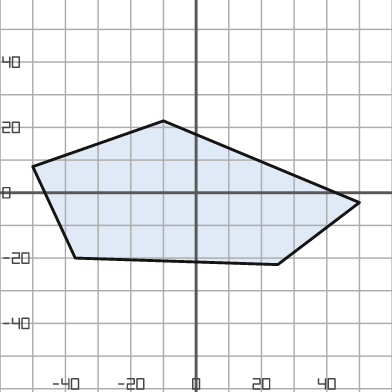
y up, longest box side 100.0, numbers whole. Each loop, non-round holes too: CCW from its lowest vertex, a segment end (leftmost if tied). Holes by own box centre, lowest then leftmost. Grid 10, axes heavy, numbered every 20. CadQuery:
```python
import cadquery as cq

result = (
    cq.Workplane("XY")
    .moveTo(25.0, -22.0)
    .lineTo(50.0, -3.0)
    .lineTo(-10.0, 22.0)
    .lineTo(-50.0, 8.0)
    .lineTo(-37.0, -20.0)
    .close()
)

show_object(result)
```